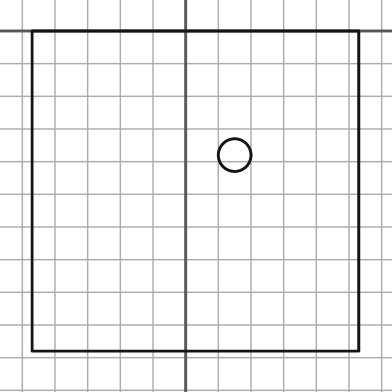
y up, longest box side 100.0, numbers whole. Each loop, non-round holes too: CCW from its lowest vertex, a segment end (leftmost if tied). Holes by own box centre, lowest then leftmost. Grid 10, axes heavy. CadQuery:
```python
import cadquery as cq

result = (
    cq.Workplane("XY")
    .moveTo(-47.0, -98.0)
    .lineTo(53.0, -98.0)
    .lineTo(53.0, 0.0)
    .lineTo(-47.0, 0.0)
    .close()
    .moveTo(15.0, -38.0)
    .circle(5.0)
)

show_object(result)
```